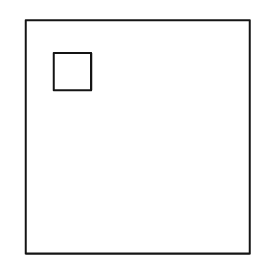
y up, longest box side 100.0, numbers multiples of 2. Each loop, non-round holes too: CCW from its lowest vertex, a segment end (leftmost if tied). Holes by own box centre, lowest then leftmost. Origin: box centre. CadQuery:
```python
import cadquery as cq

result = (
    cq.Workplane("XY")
    .moveTo(-48.0, -50.0)
    .lineTo(48.0, -50.0)
    .lineTo(48.0, 50.0)
    .lineTo(-48.0, 50.0)
    .close()
    .moveTo(-36.0, 20.0)
    .lineTo(-20.0, 20.0)
    .lineTo(-20.0, 36.0)
    .lineTo(-36.0, 36.0)
    .close()
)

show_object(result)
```